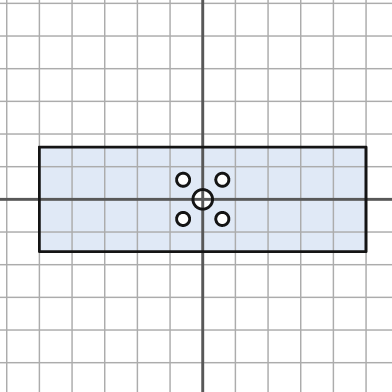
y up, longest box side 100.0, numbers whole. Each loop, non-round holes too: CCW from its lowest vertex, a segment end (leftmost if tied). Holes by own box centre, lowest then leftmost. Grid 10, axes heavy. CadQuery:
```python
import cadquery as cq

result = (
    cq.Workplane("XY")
    .moveTo(-50.0, -16.0)
    .lineTo(50.0, -16.0)
    .lineTo(50.0, 16.0)
    .lineTo(-50.0, 16.0)
    .close()
    .moveTo(-6.0, -6.0)
    .circle(2.0)
    .moveTo(6.0, -6.0)
    .circle(2.0)
    .moveTo(0.0, 0.0)
    .circle(3.0)
    .moveTo(-6.0, 6.0)
    .circle(2.0)
    .moveTo(6.0, 6.0)
    .circle(2.0)
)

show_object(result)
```